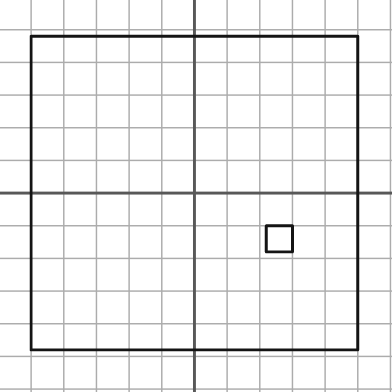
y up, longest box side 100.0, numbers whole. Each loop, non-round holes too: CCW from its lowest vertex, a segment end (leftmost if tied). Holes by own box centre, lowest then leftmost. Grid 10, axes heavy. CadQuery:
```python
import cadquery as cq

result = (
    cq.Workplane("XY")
    .moveTo(-50.0, -48.0)
    .lineTo(50.0, -48.0)
    .lineTo(50.0, 48.0)
    .lineTo(-50.0, 48.0)
    .close()
    .moveTo(22.0, -18.0)
    .lineTo(30.0, -18.0)
    .lineTo(30.0, -10.0)
    .lineTo(22.0, -10.0)
    .close()
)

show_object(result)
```